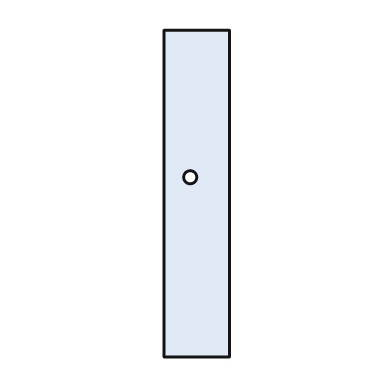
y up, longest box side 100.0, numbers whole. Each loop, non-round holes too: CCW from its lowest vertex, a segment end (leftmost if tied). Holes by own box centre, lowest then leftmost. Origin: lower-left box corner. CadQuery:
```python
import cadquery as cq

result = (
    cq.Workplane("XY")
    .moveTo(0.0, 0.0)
    .lineTo(20.0, 0.0)
    .lineTo(20.0, 100.0)
    .lineTo(0.0, 100.0)
    .close()
    .moveTo(8.0, 55.0)
    .circle(2.0)
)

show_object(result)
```